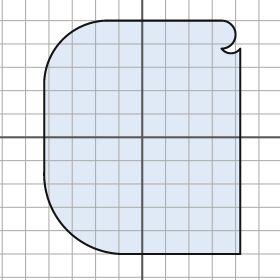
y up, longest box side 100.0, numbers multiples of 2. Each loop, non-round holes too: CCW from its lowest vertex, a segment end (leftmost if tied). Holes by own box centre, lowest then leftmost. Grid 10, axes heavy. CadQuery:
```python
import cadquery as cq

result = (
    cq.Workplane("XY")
    .moveTo(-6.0, -50.0)
    .lineTo(42.0, -50.0)
    .lineTo(42.0, 38.0)
    .threePointArc((38.0, 36.0), (34.0, 38.0))
    .threePointArc((40.0, 44.0), (34.0, 50.0))
    .lineTo(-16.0, 50.0)
    .threePointArc((-34.0, 42.0), (-42.0, 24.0))
    .lineTo(-42.0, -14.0)
    .threePointArc((-32.0, -40.0), (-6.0, -50.0))
    .close()
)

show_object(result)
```